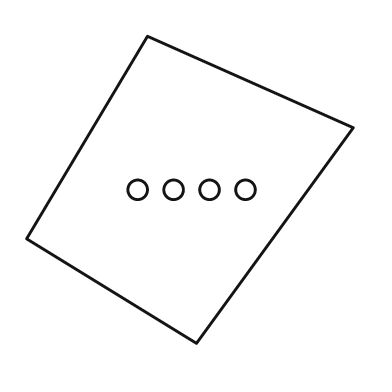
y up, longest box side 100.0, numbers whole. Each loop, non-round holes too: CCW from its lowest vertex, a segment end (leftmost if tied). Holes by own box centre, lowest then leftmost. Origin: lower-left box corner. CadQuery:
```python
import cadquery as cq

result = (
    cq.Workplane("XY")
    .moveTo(52.0, 0.0)
    .lineTo(100.0, 66.0)
    .lineTo(37.0, 94.0)
    .lineTo(0.0, 32.0)
    .close()
    .moveTo(34.0, 47.0)
    .circle(3.0)
    .moveTo(45.0, 47.0)
    .circle(3.0)
    .moveTo(56.0, 47.0)
    .circle(3.0)
    .moveTo(67.0, 47.0)
    .circle(3.0)
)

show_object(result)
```